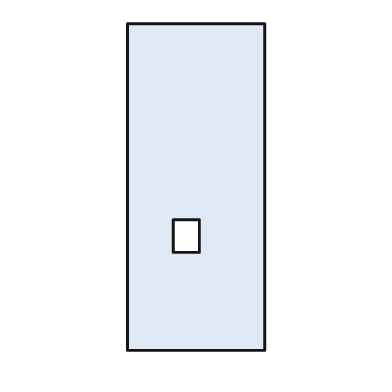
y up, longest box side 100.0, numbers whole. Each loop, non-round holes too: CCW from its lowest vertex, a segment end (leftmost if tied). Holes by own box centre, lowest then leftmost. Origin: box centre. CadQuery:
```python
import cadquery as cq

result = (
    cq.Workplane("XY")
    .moveTo(-21.0, -50.0)
    .lineTo(21.0, -50.0)
    .lineTo(21.0, 50.0)
    .lineTo(-21.0, 50.0)
    .close()
    .moveTo(-7.0, -20.0)
    .lineTo(1.0, -20.0)
    .lineTo(1.0, -10.0)
    .lineTo(-7.0, -10.0)
    .close()
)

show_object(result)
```